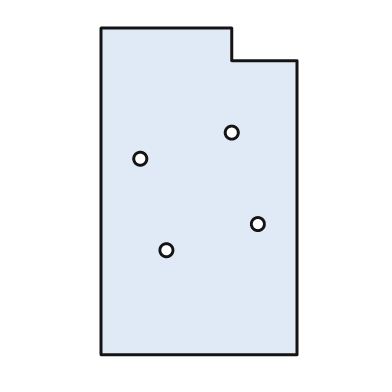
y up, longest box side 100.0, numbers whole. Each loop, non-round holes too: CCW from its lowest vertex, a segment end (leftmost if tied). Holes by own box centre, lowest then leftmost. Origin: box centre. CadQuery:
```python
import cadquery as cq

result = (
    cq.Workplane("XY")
    .moveTo(-30.0, -50.0)
    .lineTo(30.0, -50.0)
    .lineTo(30.0, 40.0)
    .lineTo(10.0, 40.0)
    .lineTo(10.0, 50.0)
    .lineTo(-30.0, 50.0)
    .close()
    .moveTo(-10.0, -18.0)
    .circle(2.0)
    .moveTo(18.0, -10.0)
    .circle(2.0)
    .moveTo(-18.0, 10.0)
    .circle(2.0)
    .moveTo(10.0, 18.0)
    .circle(2.0)
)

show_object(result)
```